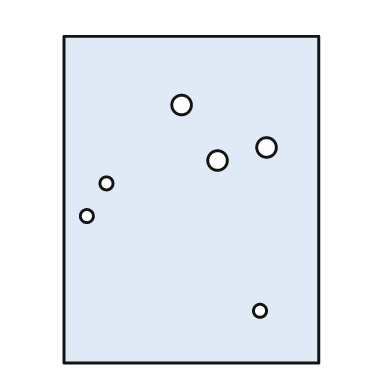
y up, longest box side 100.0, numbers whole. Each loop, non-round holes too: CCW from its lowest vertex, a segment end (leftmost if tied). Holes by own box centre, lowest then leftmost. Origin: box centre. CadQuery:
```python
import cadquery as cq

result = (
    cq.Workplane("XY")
    .moveTo(-39.0, -50.0)
    .lineTo(39.0, -50.0)
    .lineTo(39.0, 50.0)
    .lineTo(-39.0, 50.0)
    .close()
    .moveTo(21.0, -34.0)
    .circle(2.0)
    .moveTo(-32.0, -5.0)
    .circle(2.0)
    .moveTo(-26.0, 5.0)
    .circle(2.0)
    .moveTo(8.0, 12.0)
    .circle(3.0)
    .moveTo(23.0, 16.0)
    .circle(3.0)
    .moveTo(-3.0, 29.0)
    .circle(3.0)
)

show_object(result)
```